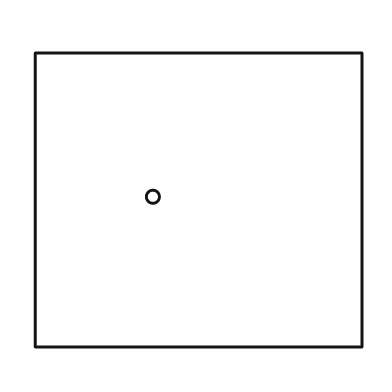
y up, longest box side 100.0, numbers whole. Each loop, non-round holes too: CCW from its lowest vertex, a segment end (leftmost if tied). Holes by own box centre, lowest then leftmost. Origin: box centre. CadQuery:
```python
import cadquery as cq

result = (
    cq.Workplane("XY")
    .moveTo(-50.0, -45.0)
    .lineTo(50.0, -45.0)
    .lineTo(50.0, 45.0)
    .lineTo(-50.0, 45.0)
    .close()
    .moveTo(-14.0, 1.0)
    .circle(2.0)
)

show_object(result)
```